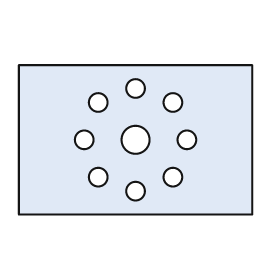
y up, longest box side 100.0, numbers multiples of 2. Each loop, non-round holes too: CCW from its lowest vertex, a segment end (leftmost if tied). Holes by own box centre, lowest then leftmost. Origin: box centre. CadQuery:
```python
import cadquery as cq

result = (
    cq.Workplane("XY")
    .moveTo(-50.0, -32.0)
    .lineTo(50.0, -32.0)
    .lineTo(50.0, 32.0)
    .lineTo(-50.0, 32.0)
    .close()
    .moveTo(0.0, -22.0)
    .circle(4.0)
    .moveTo(-16.0, -16.0)
    .circle(4.0)
    .moveTo(16.0, -16.0)
    .circle(4.0)
    .moveTo(-22.0, 0.0)
    .circle(4.0)
    .moveTo(0.0, 0.0)
    .circle(6.0)
    .moveTo(22.0, 0.0)
    .circle(4.0)
    .moveTo(-16.0, 16.0)
    .circle(4.0)
    .moveTo(16.0, 16.0)
    .circle(4.0)
    .moveTo(0.0, 22.0)
    .circle(4.0)
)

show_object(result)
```